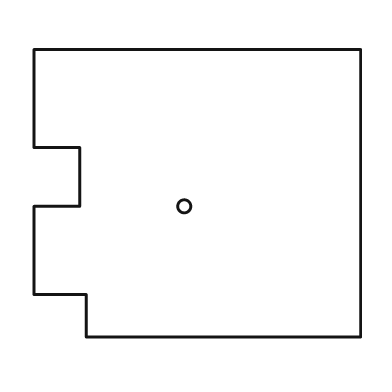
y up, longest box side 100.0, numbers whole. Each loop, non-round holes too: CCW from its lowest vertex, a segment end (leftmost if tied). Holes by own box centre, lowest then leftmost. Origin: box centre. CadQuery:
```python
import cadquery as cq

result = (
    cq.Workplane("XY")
    .moveTo(-34.0, -44.0)
    .lineTo(50.0, -44.0)
    .lineTo(50.0, 44.0)
    .lineTo(-50.0, 44.0)
    .lineTo(-50.0, 14.0)
    .lineTo(-36.0, 14.0)
    .lineTo(-36.0, -4.0)
    .lineTo(-50.0, -4.0)
    .lineTo(-50.0, -31.0)
    .lineTo(-34.0, -31.0)
    .close()
    .moveTo(-4.0, -4.0)
    .circle(2.0)
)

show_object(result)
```